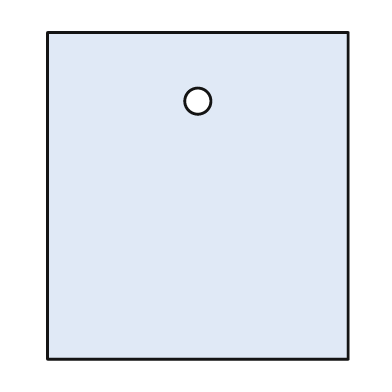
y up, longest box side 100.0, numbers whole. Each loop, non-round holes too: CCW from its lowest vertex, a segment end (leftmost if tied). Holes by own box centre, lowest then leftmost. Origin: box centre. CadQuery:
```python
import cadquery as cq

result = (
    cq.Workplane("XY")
    .moveTo(-46.0, -50.0)
    .lineTo(46.0, -50.0)
    .lineTo(46.0, 50.0)
    .lineTo(-46.0, 50.0)
    .close()
    .moveTo(0.0, 29.0)
    .circle(4.0)
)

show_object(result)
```